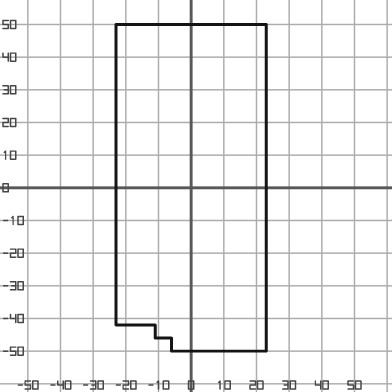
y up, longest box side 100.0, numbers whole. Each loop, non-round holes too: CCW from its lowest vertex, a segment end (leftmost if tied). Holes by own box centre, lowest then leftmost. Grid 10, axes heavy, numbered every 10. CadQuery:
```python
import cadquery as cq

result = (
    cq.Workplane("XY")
    .moveTo(-6.0, -50.0)
    .lineTo(23.0, -50.0)
    .lineTo(23.0, 50.0)
    .lineTo(-23.0, 50.0)
    .lineTo(-23.0, -42.0)
    .lineTo(-11.0, -42.0)
    .lineTo(-11.0, -46.0)
    .lineTo(-6.0, -46.0)
    .close()
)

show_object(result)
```